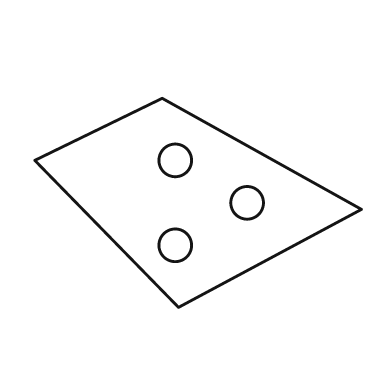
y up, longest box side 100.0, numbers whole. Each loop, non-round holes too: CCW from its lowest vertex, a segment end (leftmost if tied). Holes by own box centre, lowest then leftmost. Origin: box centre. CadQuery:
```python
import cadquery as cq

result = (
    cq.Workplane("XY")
    .moveTo(-6.0, -32.0)
    .lineTo(50.0, -2.0)
    .lineTo(-11.0, 32.0)
    .lineTo(-50.0, 13.0)
    .close()
    .moveTo(-7.0, -13.0)
    .circle(5.0)
    .moveTo(15.0, 0.0)
    .circle(5.0)
    .moveTo(-7.0, 13.0)
    .circle(5.0)
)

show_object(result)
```